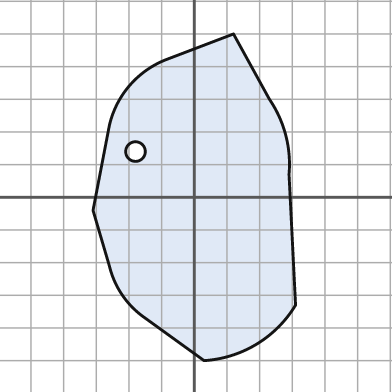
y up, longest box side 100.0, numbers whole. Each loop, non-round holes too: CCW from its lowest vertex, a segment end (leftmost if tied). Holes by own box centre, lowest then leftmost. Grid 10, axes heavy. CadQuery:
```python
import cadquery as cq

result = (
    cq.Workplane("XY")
    .moveTo(3.0, -50.0)
    .threePointArc((19.0, -45.0), (31.0, -33.0))
    .lineTo(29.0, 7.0)
    .threePointArc((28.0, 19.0), (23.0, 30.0))
    .lineTo(12.0, 50.0)
    .lineTo(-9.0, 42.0)
    .threePointArc((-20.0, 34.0), (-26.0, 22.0))
    .lineTo(-31.0, -4.0)
    .lineTo(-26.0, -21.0)
    .threePointArc((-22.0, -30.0), (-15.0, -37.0))
    .close()
    .moveTo(-18.0, 14.0)
    .circle(3.0)
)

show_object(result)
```